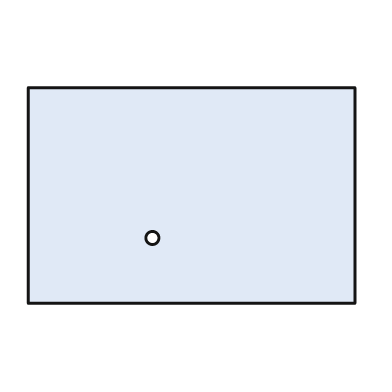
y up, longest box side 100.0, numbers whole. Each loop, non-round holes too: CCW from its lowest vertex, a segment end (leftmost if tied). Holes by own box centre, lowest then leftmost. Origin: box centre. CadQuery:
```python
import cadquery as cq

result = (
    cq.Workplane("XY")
    .moveTo(-50.0, -33.0)
    .lineTo(50.0, -33.0)
    .lineTo(50.0, 33.0)
    .lineTo(-50.0, 33.0)
    .close()
    .moveTo(-12.0, -13.0)
    .circle(2.0)
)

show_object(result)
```